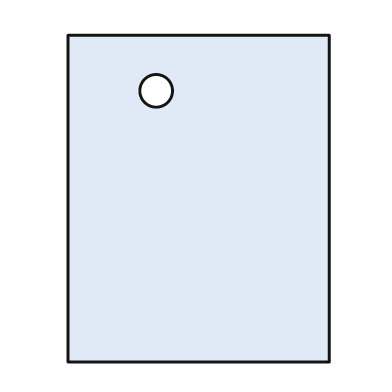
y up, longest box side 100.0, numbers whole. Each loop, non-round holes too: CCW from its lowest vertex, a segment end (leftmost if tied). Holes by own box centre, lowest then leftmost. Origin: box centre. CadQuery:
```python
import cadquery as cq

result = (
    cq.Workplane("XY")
    .moveTo(-40.0, -50.0)
    .lineTo(40.0, -50.0)
    .lineTo(40.0, 50.0)
    .lineTo(-40.0, 50.0)
    .close()
    .moveTo(-13.0, 33.0)
    .circle(5.0)
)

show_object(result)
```